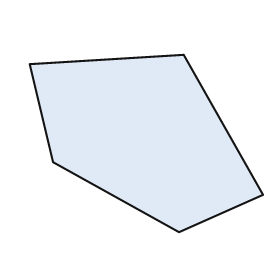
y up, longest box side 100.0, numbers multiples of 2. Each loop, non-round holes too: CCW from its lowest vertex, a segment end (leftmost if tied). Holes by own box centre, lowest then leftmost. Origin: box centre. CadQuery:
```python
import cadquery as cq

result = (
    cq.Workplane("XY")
    .moveTo(14.0, -38.0)
    .lineTo(50.0, -22.0)
    .lineTo(16.0, 38.0)
    .lineTo(-50.0, 34.0)
    .lineTo(-40.0, -8.0)
    .close()
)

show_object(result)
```